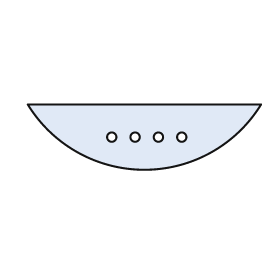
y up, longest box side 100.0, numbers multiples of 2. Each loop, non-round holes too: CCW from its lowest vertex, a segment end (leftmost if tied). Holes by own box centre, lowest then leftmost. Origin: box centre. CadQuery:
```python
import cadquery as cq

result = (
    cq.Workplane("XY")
    .moveTo(-50.0, 14.0)
    .threePointArc((0.0, -14.0), (50.0, 14.0))
    .close()
    .moveTo(-14.0, 0.0)
    .circle(2.0)
    .moveTo(-4.0, 0.0)
    .circle(2.0)
    .moveTo(6.0, 0.0)
    .circle(2.0)
    .moveTo(16.0, 0.0)
    .circle(2.0)
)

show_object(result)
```